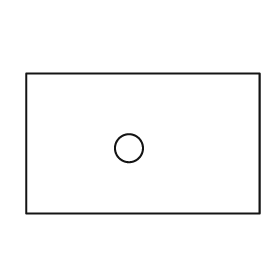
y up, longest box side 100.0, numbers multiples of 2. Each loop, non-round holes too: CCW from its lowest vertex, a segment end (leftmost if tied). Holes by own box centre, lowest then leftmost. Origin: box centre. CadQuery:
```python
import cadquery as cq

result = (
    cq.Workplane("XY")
    .moveTo(-50.0, -30.0)
    .lineTo(50.0, -30.0)
    .lineTo(50.0, 30.0)
    .lineTo(-50.0, 30.0)
    .close()
    .moveTo(-6.0, -2.0)
    .circle(6.0)
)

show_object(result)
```